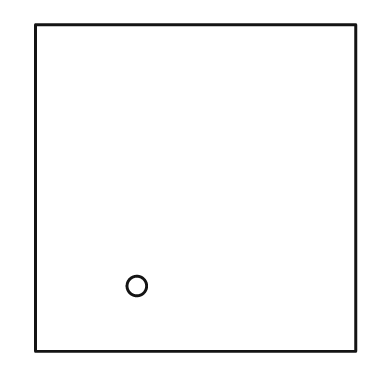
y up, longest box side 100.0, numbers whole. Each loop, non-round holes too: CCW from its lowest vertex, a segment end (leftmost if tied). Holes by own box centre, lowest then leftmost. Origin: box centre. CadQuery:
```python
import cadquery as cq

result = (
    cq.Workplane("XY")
    .moveTo(-49.0, -50.0)
    .lineTo(49.0, -50.0)
    .lineTo(49.0, 50.0)
    .lineTo(-49.0, 50.0)
    .close()
    .moveTo(-18.0, -30.0)
    .circle(3.0)
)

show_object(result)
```